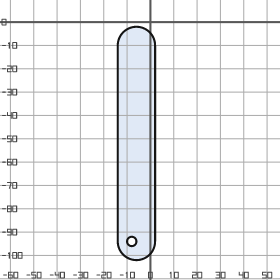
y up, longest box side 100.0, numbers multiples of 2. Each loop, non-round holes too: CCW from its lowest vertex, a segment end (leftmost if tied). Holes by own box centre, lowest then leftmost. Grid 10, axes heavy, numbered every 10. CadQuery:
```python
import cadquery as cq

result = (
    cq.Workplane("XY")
    .moveTo(-14.0, -94.0)
    .threePointArc((-6.0, -102.0), (2.0, -94.0))
    .lineTo(2.0, -10.0)
    .threePointArc((-6.0, -2.0), (-14.0, -10.0))
    .close()
    .moveTo(-8.0, -94.0)
    .circle(2.0)
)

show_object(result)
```